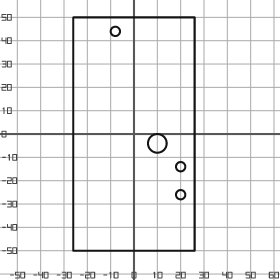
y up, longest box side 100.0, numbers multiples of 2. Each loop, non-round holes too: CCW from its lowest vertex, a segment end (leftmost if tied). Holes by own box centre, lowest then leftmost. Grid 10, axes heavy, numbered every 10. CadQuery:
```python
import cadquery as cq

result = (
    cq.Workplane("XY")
    .moveTo(-26.0, -50.0)
    .lineTo(26.0, -50.0)
    .lineTo(26.0, 50.0)
    .lineTo(-26.0, 50.0)
    .close()
    .moveTo(20.0, -26.0)
    .circle(2.0)
    .moveTo(20.0, -14.0)
    .circle(2.0)
    .moveTo(10.0, -4.0)
    .circle(4.0)
    .moveTo(-8.0, 44.0)
    .circle(2.0)
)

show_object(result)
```